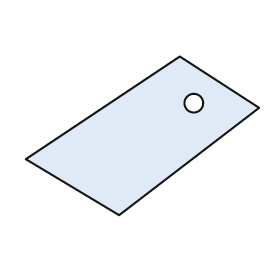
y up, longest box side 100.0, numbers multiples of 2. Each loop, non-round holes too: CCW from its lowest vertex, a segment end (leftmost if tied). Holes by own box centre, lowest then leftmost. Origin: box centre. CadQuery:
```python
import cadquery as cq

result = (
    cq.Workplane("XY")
    .moveTo(-10.0, -34.0)
    .lineTo(50.0, 12.0)
    .lineTo(16.0, 34.0)
    .lineTo(-50.0, -10.0)
    .close()
    .moveTo(22.0, 14.0)
    .circle(4.0)
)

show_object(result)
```